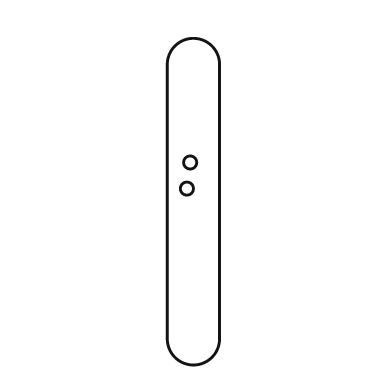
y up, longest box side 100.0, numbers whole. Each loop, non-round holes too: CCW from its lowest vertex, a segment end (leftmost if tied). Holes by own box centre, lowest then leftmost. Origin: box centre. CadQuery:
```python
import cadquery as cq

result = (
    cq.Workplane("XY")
    .moveTo(-8.0, -42.0)
    .threePointArc((0.0, -50.0), (8.0, -42.0))
    .lineTo(8.0, 42.0)
    .threePointArc((0.0, 50.0), (-8.0, 42.0))
    .close()
    .moveTo(-2.0, 4.0)
    .circle(2.0)
    .moveTo(-1.0, 12.0)
    .circle(2.0)
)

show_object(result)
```